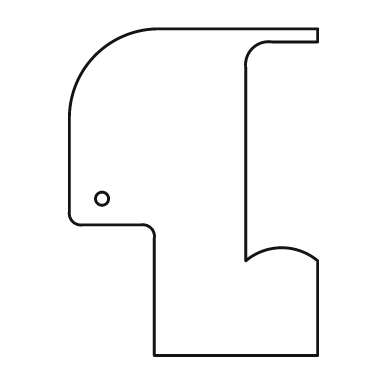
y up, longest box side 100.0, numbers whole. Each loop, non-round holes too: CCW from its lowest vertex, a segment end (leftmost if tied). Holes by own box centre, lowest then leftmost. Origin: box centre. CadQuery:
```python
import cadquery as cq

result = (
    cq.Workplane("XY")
    .moveTo(-12.0, -50.0)
    .lineTo(38.0, -50.0)
    .lineTo(38.0, -21.0)
    .threePointArc((27.0, -17.0), (16.0, -21.0))
    .lineTo(16.0, 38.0)
    .threePointArc((18.0, 44.0), (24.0, 46.0))
    .lineTo(38.0, 46.0)
    .lineTo(38.0, 50.0)
    .lineTo(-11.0, 50.0)
    .threePointArc((-30.0, 42.0), (-38.0, 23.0))
    .lineTo(-38.0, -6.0)
    .threePointArc((-37.0, -9.0), (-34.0, -10.0))
    .lineTo(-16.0, -10.0)
    .threePointArc((-13.0, -11.0), (-12.0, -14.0))
    .close()
    .moveTo(-28.0, -2.0)
    .circle(2.0)
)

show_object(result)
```